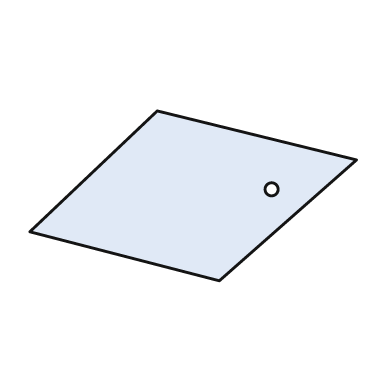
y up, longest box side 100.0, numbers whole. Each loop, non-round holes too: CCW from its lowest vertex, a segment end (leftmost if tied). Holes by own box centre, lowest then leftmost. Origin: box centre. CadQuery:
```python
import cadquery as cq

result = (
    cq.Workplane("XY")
    .moveTo(8.0, -26.0)
    .lineTo(50.0, 11.0)
    .lineTo(-11.0, 26.0)
    .lineTo(-50.0, -11.0)
    .close()
    .moveTo(24.0, 2.0)
    .circle(2.0)
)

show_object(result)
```